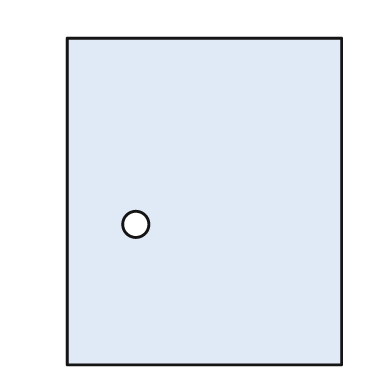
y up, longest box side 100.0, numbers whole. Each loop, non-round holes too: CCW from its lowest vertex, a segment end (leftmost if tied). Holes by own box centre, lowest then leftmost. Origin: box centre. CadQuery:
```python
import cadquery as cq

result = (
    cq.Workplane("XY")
    .moveTo(-42.0, -50.0)
    .lineTo(42.0, -50.0)
    .lineTo(42.0, 50.0)
    .lineTo(-42.0, 50.0)
    .close()
    .moveTo(-21.0, -7.0)
    .circle(4.0)
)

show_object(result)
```